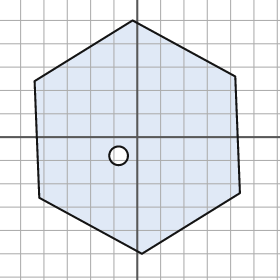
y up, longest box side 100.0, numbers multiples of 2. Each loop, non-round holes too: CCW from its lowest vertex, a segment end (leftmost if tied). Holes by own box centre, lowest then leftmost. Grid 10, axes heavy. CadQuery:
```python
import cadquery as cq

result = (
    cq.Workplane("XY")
    .moveTo(2.0, -50.0)
    .lineTo(44.0, -24.0)
    .lineTo(42.0, 26.0)
    .lineTo(-2.0, 50.0)
    .lineTo(-44.0, 24.0)
    .lineTo(-42.0, -26.0)
    .close()
    .moveTo(-8.0, -8.0)
    .circle(4.0)
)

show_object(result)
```